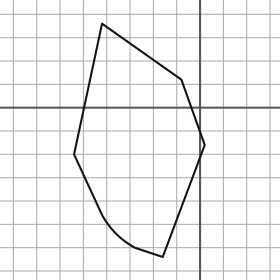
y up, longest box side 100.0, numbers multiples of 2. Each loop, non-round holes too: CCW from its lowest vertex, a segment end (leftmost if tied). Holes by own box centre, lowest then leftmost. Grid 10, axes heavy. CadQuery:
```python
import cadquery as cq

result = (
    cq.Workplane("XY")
    .moveTo(-16.0, -64.0)
    .lineTo(2.0, -16.0)
    .lineTo(-8.0, 12.0)
    .lineTo(-42.0, 36.0)
    .lineTo(-54.0, -20.0)
    .lineTo(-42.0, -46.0)
    .threePointArc((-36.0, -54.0), (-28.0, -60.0))
    .close()
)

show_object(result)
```